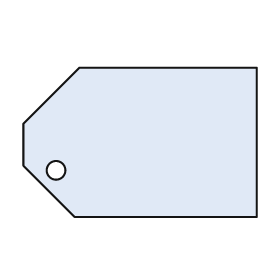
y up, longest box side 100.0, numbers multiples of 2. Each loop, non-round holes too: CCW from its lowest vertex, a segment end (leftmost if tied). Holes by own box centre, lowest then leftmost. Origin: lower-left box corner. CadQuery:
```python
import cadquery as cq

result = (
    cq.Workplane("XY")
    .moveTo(22.0, 0.0)
    .lineTo(100.0, 0.0)
    .lineTo(100.0, 64.0)
    .lineTo(24.0, 64.0)
    .lineTo(0.0, 40.0)
    .lineTo(0.0, 22.0)
    .close()
    .moveTo(14.0, 20.0)
    .circle(4.0)
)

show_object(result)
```